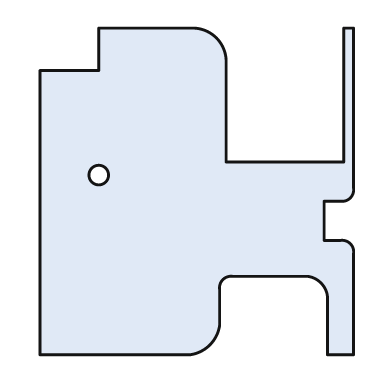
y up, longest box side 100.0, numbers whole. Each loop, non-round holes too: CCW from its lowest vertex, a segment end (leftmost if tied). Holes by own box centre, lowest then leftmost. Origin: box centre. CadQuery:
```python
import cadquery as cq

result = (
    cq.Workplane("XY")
    .moveTo(-48.0, -50.0)
    .lineTo(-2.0, -50.0)
    .threePointArc((4.0, -47.0), (7.0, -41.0))
    .lineTo(7.0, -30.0)
    .threePointArc((8.0, -27.0), (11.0, -26.0))
    .lineTo(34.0, -26.0)
    .threePointArc((38.0, -28.0), (40.0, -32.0))
    .lineTo(40.0, -50.0)
    .lineTo(48.0, -50.0)
    .lineTo(48.0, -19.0)
    .threePointArc((47.0, -16.0), (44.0, -15.0))
    .lineTo(39.0, -15.0)
    .lineTo(39.0, -3.0)
    .lineTo(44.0, -3.0)
    .threePointArc((47.0, -2.0), (48.0, 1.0))
    .lineTo(48.0, 50.0)
    .lineTo(45.0, 50.0)
    .lineTo(45.0, 9.0)
    .lineTo(9.0, 9.0)
    .lineTo(9.0, 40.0)
    .threePointArc((6.0, 47.0), (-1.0, 50.0))
    .lineTo(-30.0, 50.0)
    .lineTo(-30.0, 37.0)
    .lineTo(-48.0, 37.0)
    .close()
    .moveTo(-30.0, 5.0)
    .circle(3.0)
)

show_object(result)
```